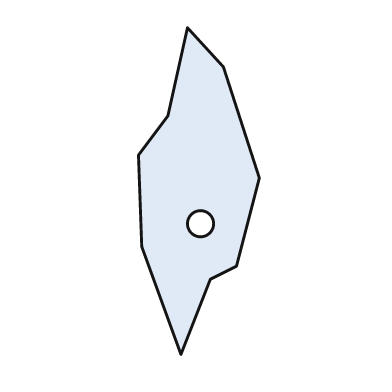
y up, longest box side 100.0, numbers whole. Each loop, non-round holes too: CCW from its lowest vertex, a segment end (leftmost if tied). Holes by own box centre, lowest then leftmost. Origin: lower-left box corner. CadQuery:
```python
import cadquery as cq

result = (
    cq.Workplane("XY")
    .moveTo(13.0, 0.0)
    .lineTo(22.0, 23.0)
    .lineTo(30.0, 27.0)
    .lineTo(37.0, 54.0)
    .lineTo(26.0, 88.0)
    .lineTo(15.0, 100.0)
    .lineTo(9.0, 73.0)
    .lineTo(0.0, 61.0)
    .lineTo(1.0, 33.0)
    .close()
    .moveTo(19.0, 40.0)
    .circle(4.0)
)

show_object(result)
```